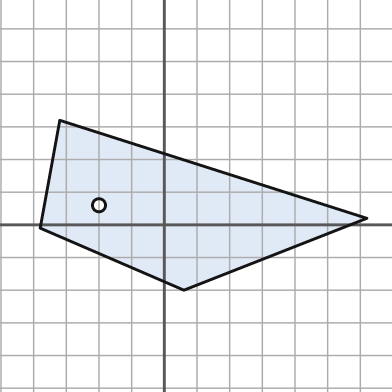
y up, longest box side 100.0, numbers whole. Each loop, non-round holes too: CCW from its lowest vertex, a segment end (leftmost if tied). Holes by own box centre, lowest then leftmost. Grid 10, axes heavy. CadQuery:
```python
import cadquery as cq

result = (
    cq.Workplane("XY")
    .moveTo(6.0, -20.0)
    .lineTo(62.0, 2.0)
    .lineTo(-32.0, 32.0)
    .lineTo(-38.0, -1.0)
    .close()
    .moveTo(-20.0, 6.0)
    .circle(2.0)
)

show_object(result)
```